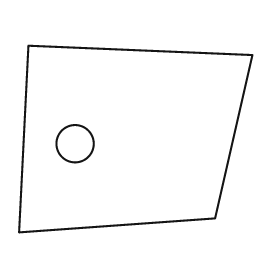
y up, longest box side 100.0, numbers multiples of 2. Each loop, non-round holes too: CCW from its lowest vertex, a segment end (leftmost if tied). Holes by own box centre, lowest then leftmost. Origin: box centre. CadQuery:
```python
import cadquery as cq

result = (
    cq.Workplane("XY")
    .moveTo(-50.0, -40.0)
    .lineTo(34.0, -34.0)
    .lineTo(50.0, 36.0)
    .lineTo(-46.0, 40.0)
    .close()
    .moveTo(-26.0, -2.0)
    .circle(8.0)
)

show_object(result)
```